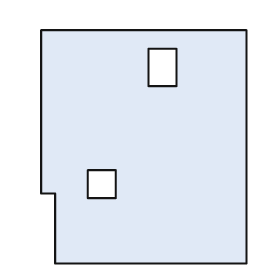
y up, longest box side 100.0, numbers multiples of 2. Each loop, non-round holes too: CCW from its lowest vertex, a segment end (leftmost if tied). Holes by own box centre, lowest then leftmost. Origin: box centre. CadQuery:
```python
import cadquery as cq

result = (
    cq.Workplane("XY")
    .moveTo(-38.0, -50.0)
    .lineTo(44.0, -50.0)
    .lineTo(44.0, 50.0)
    .lineTo(-44.0, 50.0)
    .lineTo(-44.0, -20.0)
    .lineTo(-38.0, -20.0)
    .close()
    .moveTo(-24.0, -22.0)
    .lineTo(-12.0, -22.0)
    .lineTo(-12.0, -10.0)
    .lineTo(-24.0, -10.0)
    .close()
    .moveTo(2.0, 26.0)
    .lineTo(14.0, 26.0)
    .lineTo(14.0, 42.0)
    .lineTo(2.0, 42.0)
    .close()
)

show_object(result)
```